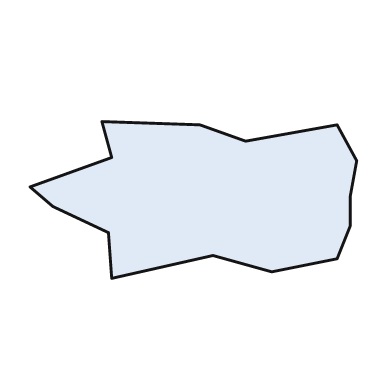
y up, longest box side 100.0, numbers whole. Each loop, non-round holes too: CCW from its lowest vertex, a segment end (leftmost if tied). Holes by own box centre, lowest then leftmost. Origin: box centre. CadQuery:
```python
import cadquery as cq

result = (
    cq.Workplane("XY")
    .moveTo(-25.0, -24.0)
    .lineTo(6.0, -17.0)
    .lineTo(24.0, -22.0)
    .lineTo(44.0, -18.0)
    .lineTo(48.0, -8.0)
    .lineTo(48.0, 1.0)
    .lineTo(50.0, 12.0)
    .lineTo(44.0, 23.0)
    .lineTo(16.0, 18.0)
    .lineTo(2.0, 23.0)
    .lineTo(-28.0, 24.0)
    .lineTo(-25.0, 13.0)
    .lineTo(-50.0, 4.0)
    .lineTo(-43.0, -2.0)
    .lineTo(-26.0, -10.0)
    .close()
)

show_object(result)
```